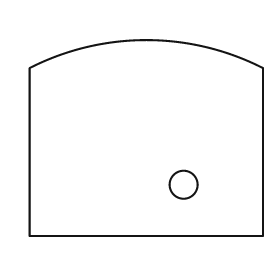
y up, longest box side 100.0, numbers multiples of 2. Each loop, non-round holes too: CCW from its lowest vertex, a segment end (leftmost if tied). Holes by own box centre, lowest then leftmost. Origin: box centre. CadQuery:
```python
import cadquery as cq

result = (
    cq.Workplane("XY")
    .moveTo(-50.0, -42.0)
    .lineTo(50.0, -42.0)
    .lineTo(50.0, 30.0)
    .threePointArc((0.0, 42.0), (-50.0, 30.0))
    .close()
    .moveTo(16.0, -20.0)
    .circle(6.0)
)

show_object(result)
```